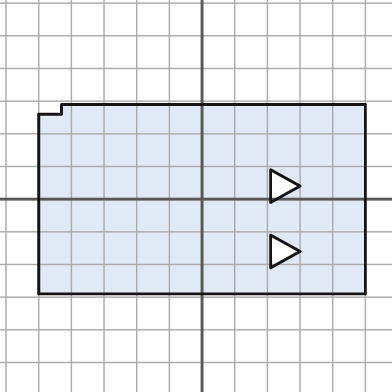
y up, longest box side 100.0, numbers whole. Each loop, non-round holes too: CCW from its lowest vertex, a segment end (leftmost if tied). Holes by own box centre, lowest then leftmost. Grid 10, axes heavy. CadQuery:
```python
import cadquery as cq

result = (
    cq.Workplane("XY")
    .moveTo(-50.0, -29.0)
    .lineTo(50.0, -29.0)
    .lineTo(50.0, 29.0)
    .lineTo(-43.0, 29.0)
    .lineTo(-43.0, 26.0)
    .lineTo(-50.0, 26.0)
    .close()
    .moveTo(21.0, -21.0)
    .lineTo(30.0, -16.0)
    .lineTo(21.0, -11.0)
    .close()
    .moveTo(21.0, -1.0)
    .lineTo(30.0, 4.0)
    .lineTo(21.0, 9.0)
    .close()
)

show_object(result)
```